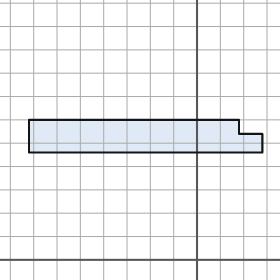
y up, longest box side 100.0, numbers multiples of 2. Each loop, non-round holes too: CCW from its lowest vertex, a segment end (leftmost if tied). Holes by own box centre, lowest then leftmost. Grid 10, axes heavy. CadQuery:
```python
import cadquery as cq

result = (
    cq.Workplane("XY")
    .moveTo(-72.0, 46.0)
    .lineTo(28.0, 46.0)
    .lineTo(28.0, 54.0)
    .lineTo(18.0, 54.0)
    .lineTo(18.0, 60.0)
    .lineTo(-72.0, 60.0)
    .close()
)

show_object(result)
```